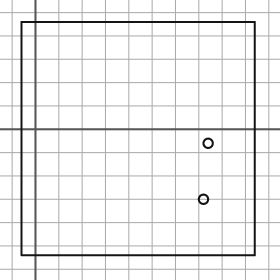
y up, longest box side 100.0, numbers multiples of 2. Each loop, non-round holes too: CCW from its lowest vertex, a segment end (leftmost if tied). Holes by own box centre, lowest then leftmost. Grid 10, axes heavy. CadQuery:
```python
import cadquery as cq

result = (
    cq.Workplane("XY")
    .moveTo(-6.0, -54.0)
    .lineTo(94.0, -54.0)
    .lineTo(94.0, 46.0)
    .lineTo(-6.0, 46.0)
    .close()
    .moveTo(72.0, -30.0)
    .circle(2.0)
    .moveTo(74.0, -6.0)
    .circle(2.0)
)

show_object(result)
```